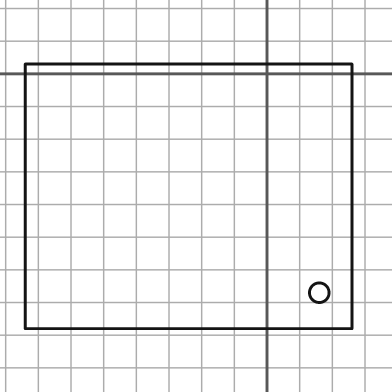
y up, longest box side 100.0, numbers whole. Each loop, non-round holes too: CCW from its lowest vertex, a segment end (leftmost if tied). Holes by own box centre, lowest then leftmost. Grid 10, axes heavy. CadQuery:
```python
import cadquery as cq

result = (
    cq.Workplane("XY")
    .moveTo(-74.0, -78.0)
    .lineTo(26.0, -78.0)
    .lineTo(26.0, 3.0)
    .lineTo(-74.0, 3.0)
    .close()
    .moveTo(16.0, -67.0)
    .circle(3.0)
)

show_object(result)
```